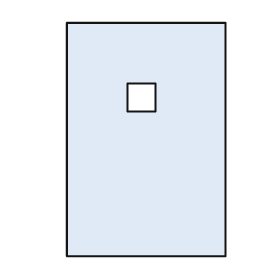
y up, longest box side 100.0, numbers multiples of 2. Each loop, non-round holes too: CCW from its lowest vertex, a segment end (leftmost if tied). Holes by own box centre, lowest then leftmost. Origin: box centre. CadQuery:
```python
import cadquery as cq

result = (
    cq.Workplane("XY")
    .moveTo(-34.0, -50.0)
    .lineTo(34.0, -50.0)
    .lineTo(34.0, 50.0)
    .lineTo(-34.0, 50.0)
    .close()
    .moveTo(-8.0, 12.0)
    .lineTo(4.0, 12.0)
    .lineTo(4.0, 24.0)
    .lineTo(-8.0, 24.0)
    .close()
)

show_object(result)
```